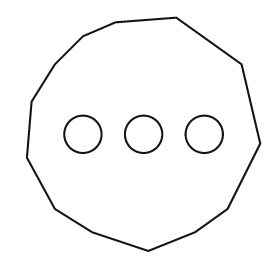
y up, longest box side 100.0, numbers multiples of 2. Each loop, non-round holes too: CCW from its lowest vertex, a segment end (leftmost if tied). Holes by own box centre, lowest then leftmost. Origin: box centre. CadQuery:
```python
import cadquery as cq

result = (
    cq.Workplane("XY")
    .moveTo(2.0, -50.0)
    .lineTo(22.0, -42.0)
    .lineTo(36.0, -32.0)
    .lineTo(50.0, -4.0)
    .lineTo(42.0, 30.0)
    .lineTo(14.0, 50.0)
    .lineTo(-12.0, 48.0)
    .lineTo(-26.0, 42.0)
    .lineTo(-38.0, 30.0)
    .lineTo(-48.0, 14.0)
    .lineTo(-50.0, -10.0)
    .lineTo(-38.0, -32.0)
    .lineTo(-22.0, -42.0)
    .close()
    .moveTo(-26.0, 0.0)
    .circle(8.0)
    .moveTo(0.0, 0.0)
    .circle(8.0)
    .moveTo(26.0, 0.0)
    .circle(8.0)
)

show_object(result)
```